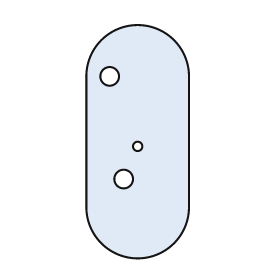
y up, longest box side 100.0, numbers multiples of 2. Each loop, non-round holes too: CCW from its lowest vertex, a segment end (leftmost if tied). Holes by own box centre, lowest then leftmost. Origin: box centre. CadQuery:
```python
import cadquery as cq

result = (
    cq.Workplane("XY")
    .moveTo(-22.0, -28.0)
    .threePointArc((0.0, -50.0), (22.0, -28.0))
    .lineTo(22.0, 28.0)
    .threePointArc((0.0, 50.0), (-22.0, 28.0))
    .close()
    .moveTo(-6.0, -16.0)
    .circle(4.0)
    .moveTo(0.0, -2.0)
    .circle(2.0)
    .moveTo(-12.0, 28.0)
    .circle(4.0)
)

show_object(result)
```